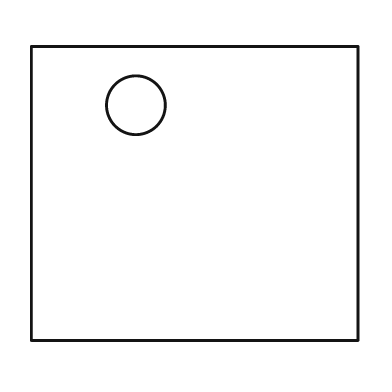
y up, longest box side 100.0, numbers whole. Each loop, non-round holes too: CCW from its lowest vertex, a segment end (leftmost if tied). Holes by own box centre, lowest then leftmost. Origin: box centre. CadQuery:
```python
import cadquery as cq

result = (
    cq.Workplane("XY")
    .moveTo(-50.0, -45.0)
    .lineTo(50.0, -45.0)
    .lineTo(50.0, 45.0)
    .lineTo(-50.0, 45.0)
    .close()
    .moveTo(-18.0, 27.0)
    .circle(9.0)
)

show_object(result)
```